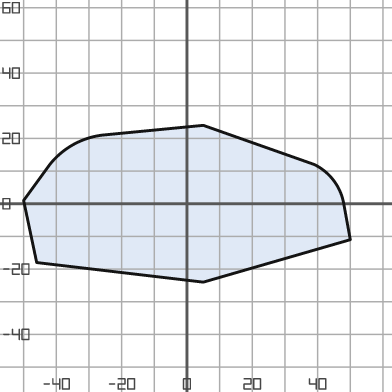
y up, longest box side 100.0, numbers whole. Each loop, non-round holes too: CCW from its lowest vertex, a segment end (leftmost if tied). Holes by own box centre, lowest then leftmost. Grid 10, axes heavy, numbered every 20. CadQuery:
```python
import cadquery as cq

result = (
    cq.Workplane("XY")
    .moveTo(5.0, -24.0)
    .lineTo(50.0, -11.0)
    .lineTo(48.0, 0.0)
    .threePointArc((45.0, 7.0), (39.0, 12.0))
    .lineTo(5.0, 24.0)
    .lineTo(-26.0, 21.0)
    .threePointArc((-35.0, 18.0), (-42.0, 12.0))
    .lineTo(-50.0, 1.0)
    .lineTo(-46.0, -18.0)
    .close()
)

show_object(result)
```